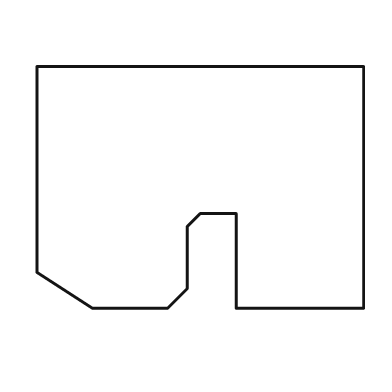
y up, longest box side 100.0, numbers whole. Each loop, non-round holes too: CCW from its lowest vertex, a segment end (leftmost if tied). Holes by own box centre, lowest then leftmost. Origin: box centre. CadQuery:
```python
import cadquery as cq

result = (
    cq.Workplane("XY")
    .moveTo(-33.0, -37.0)
    .lineTo(-10.0, -37.0)
    .lineTo(-4.0, -31.0)
    .lineTo(-4.0, -12.0)
    .lineTo(0.0, -8.0)
    .lineTo(11.0, -8.0)
    .lineTo(11.0, -37.0)
    .lineTo(50.0, -37.0)
    .lineTo(50.0, 37.0)
    .lineTo(-50.0, 37.0)
    .lineTo(-50.0, -26.0)
    .close()
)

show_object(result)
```